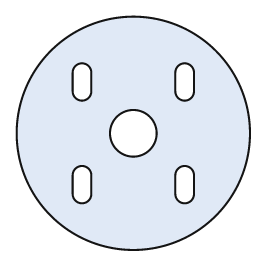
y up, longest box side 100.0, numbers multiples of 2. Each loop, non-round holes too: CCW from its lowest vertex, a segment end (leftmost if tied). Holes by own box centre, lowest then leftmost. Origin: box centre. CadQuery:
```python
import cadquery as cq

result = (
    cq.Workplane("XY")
    .moveTo(0.0, 0.0)
    .circle(50.0)
    .moveTo(-26.0, -26.0)
    .threePointArc((-22.0, -30.0), (-18.0, -26.0))
    .lineTo(-18.0, -18.0)
    .threePointArc((-22.0, -14.0), (-26.0, -18.0))
    .close()
    .moveTo(18.0, -26.0)
    .threePointArc((22.0, -30.0), (26.0, -26.0))
    .lineTo(26.0, -18.0)
    .threePointArc((22.0, -14.0), (18.0, -18.0))
    .close()
    .moveTo(0.0, 0.0)
    .circle(10.0)
    .moveTo(-26.0, 18.0)
    .threePointArc((-22.0, 14.0), (-18.0, 18.0))
    .lineTo(-18.0, 26.0)
    .threePointArc((-22.0, 30.0), (-26.0, 26.0))
    .close()
    .moveTo(18.0, 18.0)
    .threePointArc((22.0, 14.0), (26.0, 18.0))
    .lineTo(26.0, 26.0)
    .threePointArc((22.0, 30.0), (18.0, 26.0))
    .close()
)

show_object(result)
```